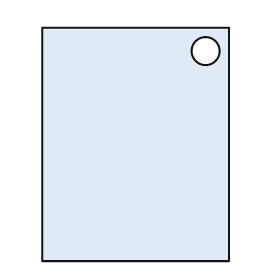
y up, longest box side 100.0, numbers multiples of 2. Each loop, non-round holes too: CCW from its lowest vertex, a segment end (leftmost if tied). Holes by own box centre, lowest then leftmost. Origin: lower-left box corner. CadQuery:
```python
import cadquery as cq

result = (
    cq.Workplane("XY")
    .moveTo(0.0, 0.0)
    .lineTo(80.0, 0.0)
    .lineTo(80.0, 100.0)
    .lineTo(0.0, 100.0)
    .close()
    .moveTo(70.0, 90.0)
    .circle(6.0)
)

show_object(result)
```